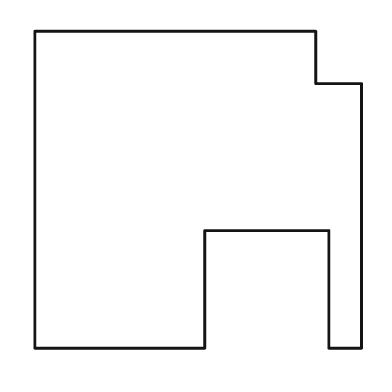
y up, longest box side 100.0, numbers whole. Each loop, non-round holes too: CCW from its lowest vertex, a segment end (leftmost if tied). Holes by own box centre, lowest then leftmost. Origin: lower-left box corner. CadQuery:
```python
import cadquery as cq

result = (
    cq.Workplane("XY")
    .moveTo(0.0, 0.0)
    .lineTo(52.0, 0.0)
    .lineTo(52.0, 36.0)
    .lineTo(90.0, 36.0)
    .lineTo(90.0, 0.0)
    .lineTo(100.0, 0.0)
    .lineTo(100.0, 81.0)
    .lineTo(86.0, 81.0)
    .lineTo(86.0, 97.0)
    .lineTo(0.0, 97.0)
    .close()
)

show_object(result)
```